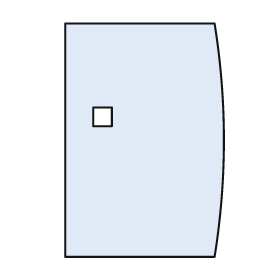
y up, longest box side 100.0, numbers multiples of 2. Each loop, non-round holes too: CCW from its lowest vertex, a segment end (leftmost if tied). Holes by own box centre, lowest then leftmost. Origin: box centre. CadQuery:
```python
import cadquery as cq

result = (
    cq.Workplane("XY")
    .moveTo(-34.0, -50.0)
    .lineTo(30.0, -50.0)
    .threePointArc((34.0, 0.0), (30.0, 50.0))
    .lineTo(-34.0, 50.0)
    .close()
    .moveTo(-22.0, 6.0)
    .lineTo(-14.0, 6.0)
    .lineTo(-14.0, 14.0)
    .lineTo(-22.0, 14.0)
    .close()
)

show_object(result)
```